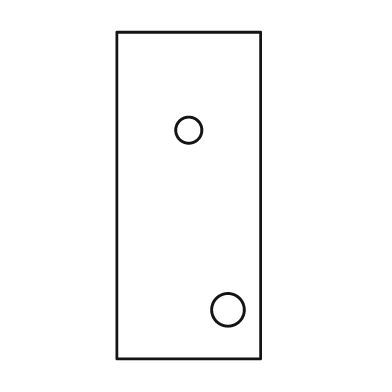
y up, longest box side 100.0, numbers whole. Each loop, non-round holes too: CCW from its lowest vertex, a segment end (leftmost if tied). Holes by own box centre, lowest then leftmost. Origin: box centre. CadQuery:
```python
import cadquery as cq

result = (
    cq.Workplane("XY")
    .moveTo(-22.0, -50.0)
    .lineTo(22.0, -50.0)
    .lineTo(22.0, 50.0)
    .lineTo(-22.0, 50.0)
    .close()
    .moveTo(12.0, -35.0)
    .circle(5.0)
    .moveTo(0.0, 20.0)
    .circle(4.0)
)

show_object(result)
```